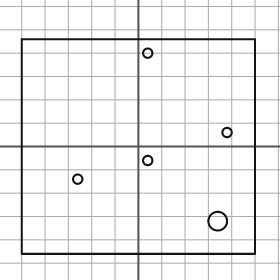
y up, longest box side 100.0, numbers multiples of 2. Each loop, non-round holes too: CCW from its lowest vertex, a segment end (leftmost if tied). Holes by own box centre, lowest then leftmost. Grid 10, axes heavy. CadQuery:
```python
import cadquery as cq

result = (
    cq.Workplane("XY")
    .moveTo(-50.0, -46.0)
    .lineTo(50.0, -46.0)
    .lineTo(50.0, 46.0)
    .lineTo(-50.0, 46.0)
    .close()
    .moveTo(34.0, -32.0)
    .circle(4.0)
    .moveTo(-26.0, -14.0)
    .circle(2.0)
    .moveTo(4.0, -6.0)
    .circle(2.0)
    .moveTo(38.0, 6.0)
    .circle(2.0)
    .moveTo(4.0, 40.0)
    .circle(2.0)
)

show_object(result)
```